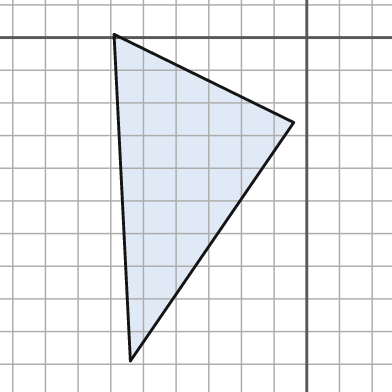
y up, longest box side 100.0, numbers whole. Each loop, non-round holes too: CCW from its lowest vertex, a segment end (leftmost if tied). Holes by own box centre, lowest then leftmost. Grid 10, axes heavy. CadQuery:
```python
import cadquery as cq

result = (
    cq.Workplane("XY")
    .moveTo(-54.0, -99.0)
    .lineTo(-4.0, -26.0)
    .lineTo(-59.0, 1.0)
    .close()
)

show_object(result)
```